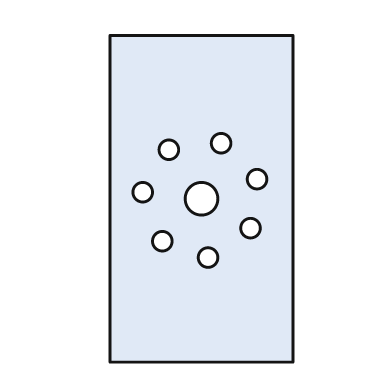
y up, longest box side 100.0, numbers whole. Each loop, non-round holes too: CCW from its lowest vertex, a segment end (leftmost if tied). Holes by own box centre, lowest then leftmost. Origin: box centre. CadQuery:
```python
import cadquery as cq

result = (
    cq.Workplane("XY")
    .moveTo(-28.0, -50.0)
    .lineTo(28.0, -50.0)
    .lineTo(28.0, 50.0)
    .lineTo(-28.0, 50.0)
    .close()
    .moveTo(2.0, -18.0)
    .circle(3.0)
    .moveTo(-12.0, -13.0)
    .circle(3.0)
    .moveTo(15.0, -9.0)
    .circle(3.0)
    .moveTo(0.0, 0.0)
    .circle(5.0)
    .moveTo(-18.0, 2.0)
    .circle(3.0)
    .moveTo(17.0, 6.0)
    .circle(3.0)
    .moveTo(-10.0, 15.0)
    .circle(3.0)
    .moveTo(6.0, 17.0)
    .circle(3.0)
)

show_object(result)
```